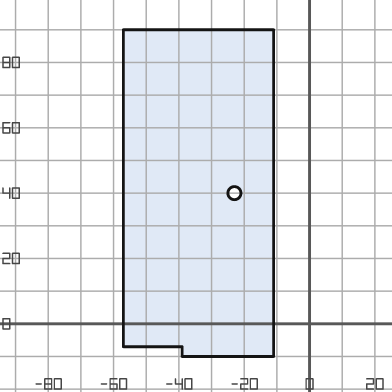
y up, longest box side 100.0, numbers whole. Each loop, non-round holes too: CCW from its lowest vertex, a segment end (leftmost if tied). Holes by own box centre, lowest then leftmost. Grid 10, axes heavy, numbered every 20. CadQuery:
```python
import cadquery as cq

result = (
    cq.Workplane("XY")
    .moveTo(-39.0, -10.0)
    .lineTo(-11.0, -10.0)
    .lineTo(-11.0, 90.0)
    .lineTo(-57.0, 90.0)
    .lineTo(-57.0, -7.0)
    .lineTo(-39.0, -7.0)
    .close()
    .moveTo(-23.0, 40.0)
    .circle(2.0)
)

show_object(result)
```